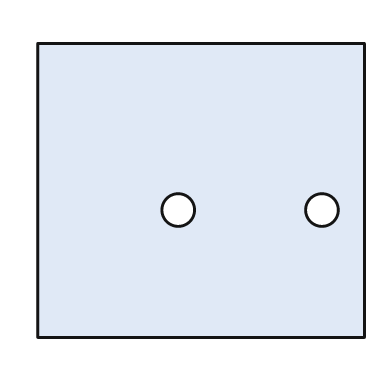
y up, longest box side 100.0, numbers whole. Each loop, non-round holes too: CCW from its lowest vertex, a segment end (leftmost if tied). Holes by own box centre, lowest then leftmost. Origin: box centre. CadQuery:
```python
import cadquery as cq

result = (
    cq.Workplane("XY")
    .moveTo(-50.0, -45.0)
    .lineTo(50.0, -45.0)
    .lineTo(50.0, 45.0)
    .lineTo(-50.0, 45.0)
    .close()
    .moveTo(-7.0, -6.0)
    .circle(5.0)
    .moveTo(37.0, -6.0)
    .circle(5.0)
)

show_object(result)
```